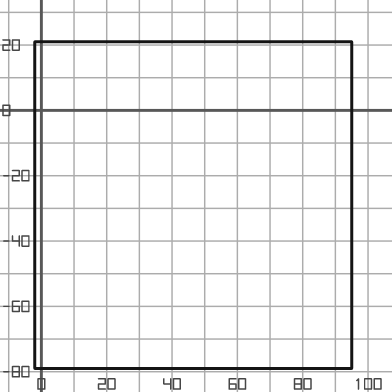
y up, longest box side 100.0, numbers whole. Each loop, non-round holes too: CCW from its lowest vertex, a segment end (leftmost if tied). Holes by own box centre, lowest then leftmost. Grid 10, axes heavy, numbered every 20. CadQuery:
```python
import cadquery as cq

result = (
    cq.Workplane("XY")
    .moveTo(-2.0, -79.0)
    .lineTo(95.0, -79.0)
    .lineTo(95.0, 21.0)
    .lineTo(-2.0, 21.0)
    .close()
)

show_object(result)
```